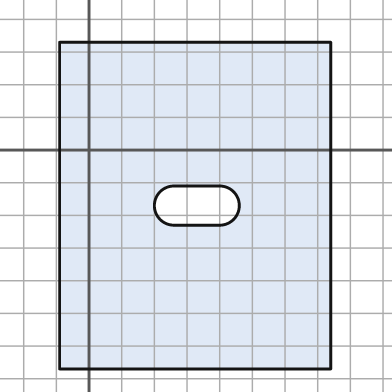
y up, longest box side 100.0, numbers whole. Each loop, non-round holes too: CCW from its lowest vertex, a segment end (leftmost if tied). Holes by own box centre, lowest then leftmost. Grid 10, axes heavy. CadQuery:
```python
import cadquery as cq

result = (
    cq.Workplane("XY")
    .moveTo(-9.0, -67.0)
    .lineTo(74.0, -67.0)
    .lineTo(74.0, 33.0)
    .lineTo(-9.0, 33.0)
    .close()
    .moveTo(26.0, -23.0)
    .lineTo(40.0, -23.0)
    .threePointArc((46.0, -17.0), (40.0, -11.0))
    .lineTo(26.0, -11.0)
    .threePointArc((20.0, -17.0), (26.0, -23.0))
    .close()
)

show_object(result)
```